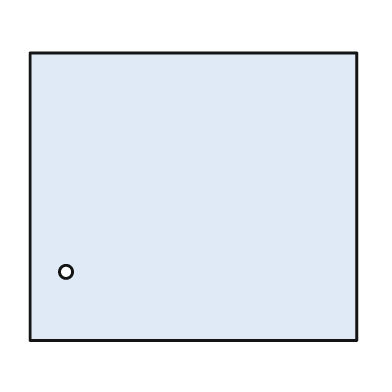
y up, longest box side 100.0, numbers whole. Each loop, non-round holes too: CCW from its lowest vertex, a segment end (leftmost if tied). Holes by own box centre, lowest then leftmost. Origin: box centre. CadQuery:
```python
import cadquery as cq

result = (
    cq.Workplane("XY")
    .moveTo(-50.0, -44.0)
    .lineTo(50.0, -44.0)
    .lineTo(50.0, 44.0)
    .lineTo(-50.0, 44.0)
    .close()
    .moveTo(-39.0, -23.0)
    .circle(2.0)
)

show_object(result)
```